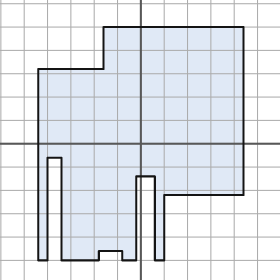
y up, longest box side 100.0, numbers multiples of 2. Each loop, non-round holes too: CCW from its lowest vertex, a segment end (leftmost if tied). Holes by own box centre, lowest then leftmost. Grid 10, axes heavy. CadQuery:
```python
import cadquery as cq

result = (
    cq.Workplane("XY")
    .moveTo(-44.0, -50.0)
    .lineTo(-40.0, -50.0)
    .lineTo(-40.0, -6.0)
    .lineTo(-34.0, -6.0)
    .lineTo(-34.0, -50.0)
    .lineTo(-18.0, -50.0)
    .lineTo(-18.0, -46.0)
    .lineTo(-8.0, -46.0)
    .lineTo(-8.0, -50.0)
    .lineTo(-2.0, -50.0)
    .lineTo(-2.0, -14.0)
    .lineTo(6.0, -14.0)
    .lineTo(6.0, -50.0)
    .lineTo(10.0, -50.0)
    .lineTo(10.0, -22.0)
    .lineTo(44.0, -22.0)
    .lineTo(44.0, 50.0)
    .lineTo(-16.0, 50.0)
    .lineTo(-16.0, 32.0)
    .lineTo(-44.0, 32.0)
    .close()
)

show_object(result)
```